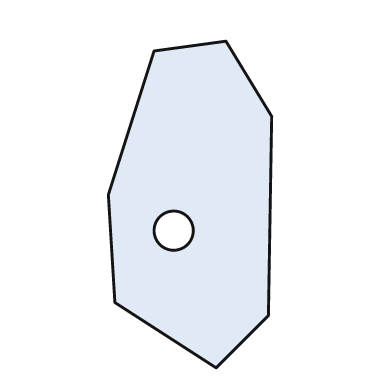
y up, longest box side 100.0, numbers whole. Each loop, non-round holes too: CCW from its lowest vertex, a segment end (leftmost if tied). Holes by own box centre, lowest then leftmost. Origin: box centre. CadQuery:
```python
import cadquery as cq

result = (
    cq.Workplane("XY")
    .moveTo(8.0, -50.0)
    .lineTo(24.0, -34.0)
    .lineTo(25.0, 27.0)
    .lineTo(11.0, 50.0)
    .lineTo(-11.0, 47.0)
    .lineTo(-25.0, 3.0)
    .lineTo(-23.0, -30.0)
    .close()
    .moveTo(-5.0, -8.0)
    .circle(6.0)
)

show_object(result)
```